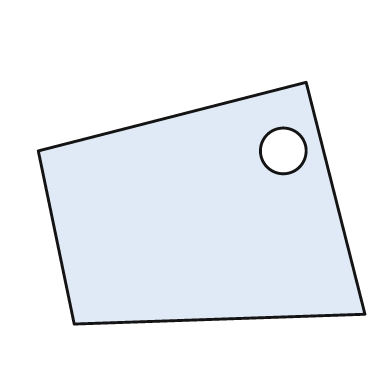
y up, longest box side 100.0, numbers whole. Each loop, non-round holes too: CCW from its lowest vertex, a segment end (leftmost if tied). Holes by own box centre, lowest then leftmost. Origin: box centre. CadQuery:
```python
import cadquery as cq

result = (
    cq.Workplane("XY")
    .moveTo(-39.0, -37.0)
    .lineTo(50.0, -34.0)
    .lineTo(32.0, 37.0)
    .lineTo(-50.0, 16.0)
    .close()
    .moveTo(25.0, 16.0)
    .circle(7.0)
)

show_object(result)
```